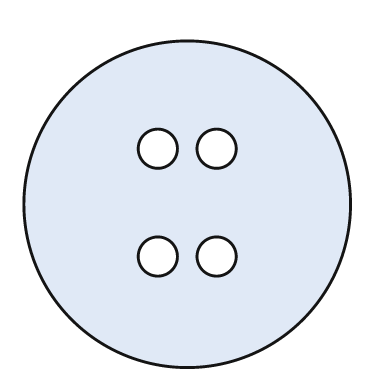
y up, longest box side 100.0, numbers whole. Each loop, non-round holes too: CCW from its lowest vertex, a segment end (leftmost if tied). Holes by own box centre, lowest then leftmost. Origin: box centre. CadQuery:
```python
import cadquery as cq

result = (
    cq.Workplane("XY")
    .moveTo(0.0, 0.0)
    .circle(50.0)
    .moveTo(-9.0, -16.0)
    .circle(6.0)
    .moveTo(9.0, -16.0)
    .circle(6.0)
    .moveTo(-9.0, 17.0)
    .circle(6.0)
    .moveTo(9.0, 17.0)
    .circle(6.0)
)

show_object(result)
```